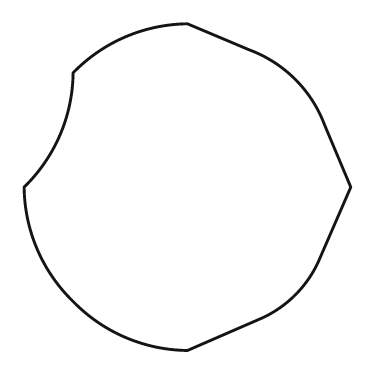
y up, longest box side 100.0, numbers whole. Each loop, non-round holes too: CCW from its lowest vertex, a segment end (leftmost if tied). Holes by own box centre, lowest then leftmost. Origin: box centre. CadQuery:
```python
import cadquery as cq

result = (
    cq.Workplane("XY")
    .moveTo(0.0, -50.0)
    .lineTo(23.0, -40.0)
    .threePointArc((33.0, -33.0), (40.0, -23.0))
    .lineTo(50.0, 0.0)
    .lineTo(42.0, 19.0)
    .threePointArc((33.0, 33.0), (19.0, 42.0))
    .lineTo(0.0, 50.0)
    .threePointArc((-19.0, 46.0), (-35.0, 35.0))
    .threePointArc((-39.0, 16.0), (-50.0, 0.0))
    .threePointArc((-46.0, -19.0), (-35.0, -35.0))
    .threePointArc((-19.0, -46.0), (0.0, -50.0))
    .close()
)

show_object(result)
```